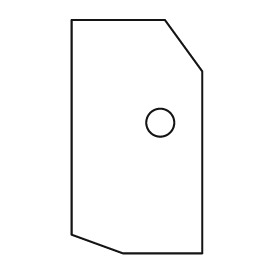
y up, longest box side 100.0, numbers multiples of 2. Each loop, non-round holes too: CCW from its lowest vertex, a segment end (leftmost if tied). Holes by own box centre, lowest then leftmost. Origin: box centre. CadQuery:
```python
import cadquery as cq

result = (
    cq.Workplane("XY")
    .moveTo(-6.0, -50.0)
    .lineTo(28.0, -50.0)
    .lineTo(28.0, 28.0)
    .lineTo(12.0, 50.0)
    .lineTo(-28.0, 50.0)
    .lineTo(-28.0, -42.0)
    .close()
    .moveTo(10.0, 6.0)
    .circle(6.0)
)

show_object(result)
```